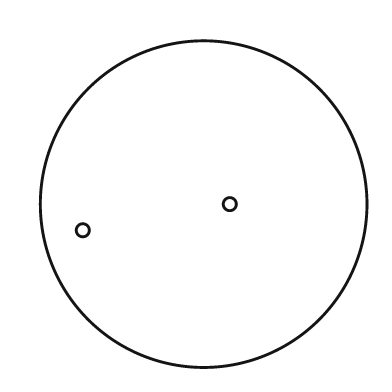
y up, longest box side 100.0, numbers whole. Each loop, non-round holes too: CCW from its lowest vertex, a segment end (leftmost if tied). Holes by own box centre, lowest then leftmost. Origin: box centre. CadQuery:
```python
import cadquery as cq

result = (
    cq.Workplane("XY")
    .moveTo(0.0, 0.0)
    .circle(50.0)
    .moveTo(-37.0, -8.0)
    .circle(2.0)
    .moveTo(8.0, 0.0)
    .circle(2.0)
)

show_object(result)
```